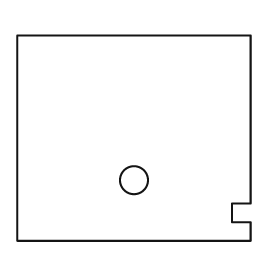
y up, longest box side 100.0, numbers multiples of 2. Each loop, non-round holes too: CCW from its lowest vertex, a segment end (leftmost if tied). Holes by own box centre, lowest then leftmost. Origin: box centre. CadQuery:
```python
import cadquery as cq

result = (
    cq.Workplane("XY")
    .moveTo(-50.0, -44.0)
    .lineTo(50.0, -44.0)
    .lineTo(50.0, -36.0)
    .lineTo(42.0, -36.0)
    .lineTo(42.0, -28.0)
    .lineTo(50.0, -28.0)
    .lineTo(50.0, 44.0)
    .lineTo(-50.0, 44.0)
    .close()
    .moveTo(0.0, -18.0)
    .circle(6.0)
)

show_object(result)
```